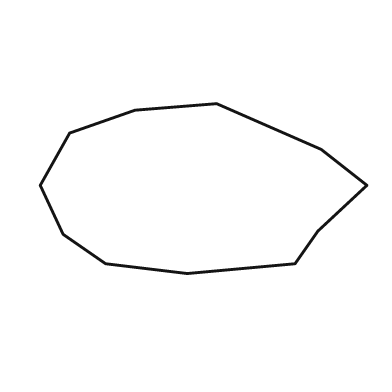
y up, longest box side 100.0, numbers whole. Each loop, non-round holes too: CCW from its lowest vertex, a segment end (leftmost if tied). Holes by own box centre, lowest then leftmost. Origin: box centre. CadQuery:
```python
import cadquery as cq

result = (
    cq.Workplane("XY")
    .moveTo(-5.0, -26.0)
    .lineTo(28.0, -23.0)
    .lineTo(35.0, -13.0)
    .lineTo(50.0, 1.0)
    .lineTo(36.0, 12.0)
    .lineTo(4.0, 26.0)
    .lineTo(-21.0, 24.0)
    .lineTo(-41.0, 17.0)
    .lineTo(-50.0, 1.0)
    .lineTo(-43.0, -14.0)
    .lineTo(-30.0, -23.0)
    .close()
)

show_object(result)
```